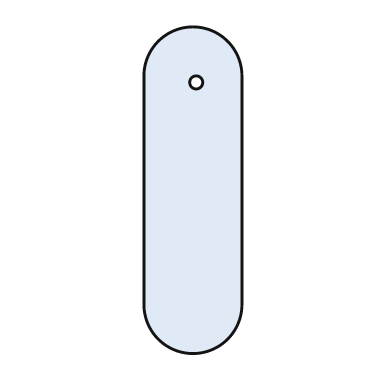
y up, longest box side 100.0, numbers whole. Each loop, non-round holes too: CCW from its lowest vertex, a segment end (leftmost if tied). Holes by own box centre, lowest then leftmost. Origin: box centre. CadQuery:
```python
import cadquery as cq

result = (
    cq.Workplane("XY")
    .moveTo(-15.0, -35.0)
    .threePointArc((0.0, -50.0), (15.0, -35.0))
    .lineTo(15.0, 35.0)
    .threePointArc((0.0, 50.0), (-15.0, 35.0))
    .close()
    .moveTo(1.0, 33.0)
    .circle(2.0)
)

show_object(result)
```